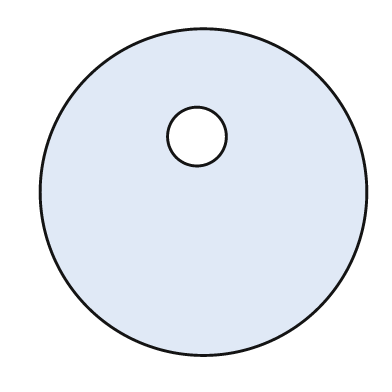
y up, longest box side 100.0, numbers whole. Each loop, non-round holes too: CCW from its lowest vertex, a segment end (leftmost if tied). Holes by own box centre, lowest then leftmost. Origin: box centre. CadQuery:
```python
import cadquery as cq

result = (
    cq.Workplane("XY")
    .moveTo(0.0, 0.0)
    .circle(50.0)
    .moveTo(-2.0, 17.0)
    .circle(9.0)
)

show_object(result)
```